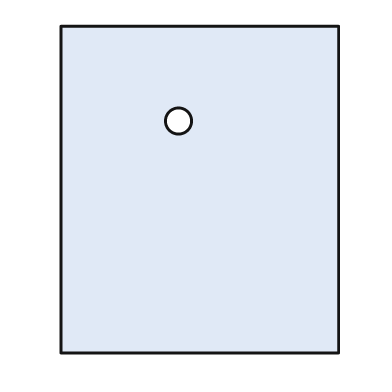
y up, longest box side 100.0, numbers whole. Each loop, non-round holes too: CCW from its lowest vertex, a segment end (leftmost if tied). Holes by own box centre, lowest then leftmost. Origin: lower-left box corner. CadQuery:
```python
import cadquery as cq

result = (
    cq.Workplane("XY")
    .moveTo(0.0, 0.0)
    .lineTo(85.0, 0.0)
    .lineTo(85.0, 100.0)
    .lineTo(0.0, 100.0)
    .close()
    .moveTo(36.0, 71.0)
    .circle(4.0)
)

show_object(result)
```